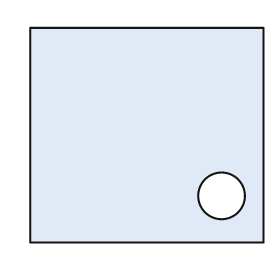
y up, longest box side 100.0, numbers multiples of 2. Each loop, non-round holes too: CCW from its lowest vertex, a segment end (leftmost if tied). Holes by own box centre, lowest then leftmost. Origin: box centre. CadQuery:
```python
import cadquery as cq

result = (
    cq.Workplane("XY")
    .moveTo(-50.0, -46.0)
    .lineTo(50.0, -46.0)
    .lineTo(50.0, 46.0)
    .lineTo(-50.0, 46.0)
    .close()
    .moveTo(32.0, -26.0)
    .circle(10.0)
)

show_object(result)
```